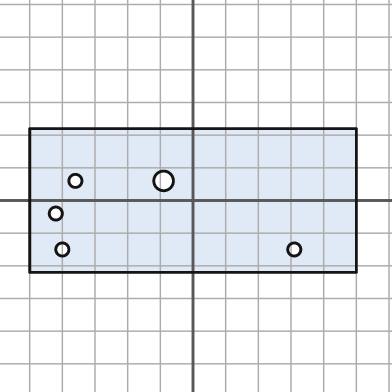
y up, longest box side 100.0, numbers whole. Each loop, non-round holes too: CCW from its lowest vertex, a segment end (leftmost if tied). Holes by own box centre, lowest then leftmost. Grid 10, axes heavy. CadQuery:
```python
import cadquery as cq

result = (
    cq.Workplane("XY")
    .moveTo(-50.0, -22.0)
    .lineTo(50.0, -22.0)
    .lineTo(50.0, 22.0)
    .lineTo(-50.0, 22.0)
    .close()
    .moveTo(-40.0, -15.0)
    .circle(2.0)
    .moveTo(31.0, -15.0)
    .circle(2.0)
    .moveTo(-42.0, -4.0)
    .circle(2.0)
    .moveTo(-36.0, 6.0)
    .circle(2.0)
    .moveTo(-9.0, 6.0)
    .circle(3.0)
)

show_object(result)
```